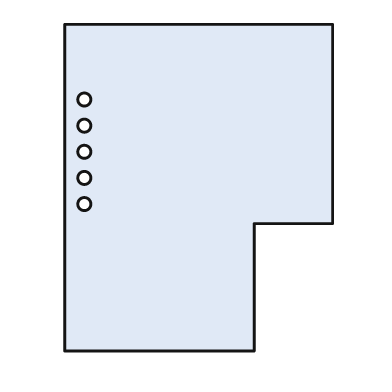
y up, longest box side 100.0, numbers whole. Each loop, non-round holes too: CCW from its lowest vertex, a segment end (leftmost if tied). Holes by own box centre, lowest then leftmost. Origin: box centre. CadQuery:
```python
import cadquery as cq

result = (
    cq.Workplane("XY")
    .moveTo(-41.0, -50.0)
    .lineTo(17.0, -50.0)
    .lineTo(17.0, -11.0)
    .lineTo(41.0, -11.0)
    .lineTo(41.0, 50.0)
    .lineTo(-41.0, 50.0)
    .close()
    .moveTo(-35.0, -5.0)
    .circle(2.0)
    .moveTo(-35.0, 3.0)
    .circle(2.0)
    .moveTo(-35.0, 11.0)
    .circle(2.0)
    .moveTo(-35.0, 19.0)
    .circle(2.0)
    .moveTo(-35.0, 27.0)
    .circle(2.0)
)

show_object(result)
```